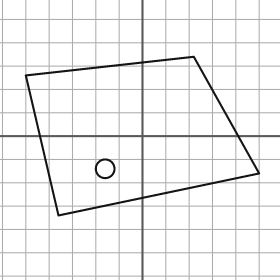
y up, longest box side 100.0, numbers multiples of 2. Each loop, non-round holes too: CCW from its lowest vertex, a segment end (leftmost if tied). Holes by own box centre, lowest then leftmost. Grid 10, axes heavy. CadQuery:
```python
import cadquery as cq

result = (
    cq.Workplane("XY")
    .moveTo(-36.0, -34.0)
    .lineTo(50.0, -16.0)
    .lineTo(22.0, 34.0)
    .lineTo(-50.0, 26.0)
    .close()
    .moveTo(-16.0, -14.0)
    .circle(4.0)
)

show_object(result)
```